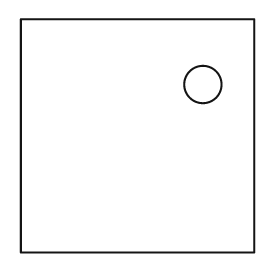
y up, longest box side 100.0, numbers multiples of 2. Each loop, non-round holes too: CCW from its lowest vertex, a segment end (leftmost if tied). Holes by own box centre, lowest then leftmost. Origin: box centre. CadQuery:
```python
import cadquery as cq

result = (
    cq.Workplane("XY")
    .moveTo(-50.0, -50.0)
    .lineTo(50.0, -50.0)
    .lineTo(50.0, 50.0)
    .lineTo(-50.0, 50.0)
    .close()
    .moveTo(28.0, 22.0)
    .circle(8.0)
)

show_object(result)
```